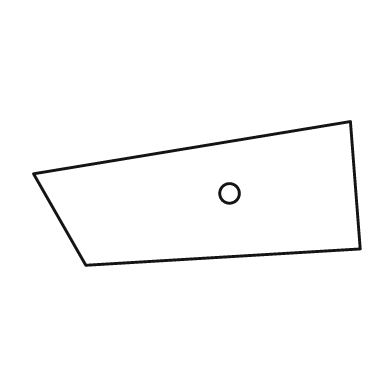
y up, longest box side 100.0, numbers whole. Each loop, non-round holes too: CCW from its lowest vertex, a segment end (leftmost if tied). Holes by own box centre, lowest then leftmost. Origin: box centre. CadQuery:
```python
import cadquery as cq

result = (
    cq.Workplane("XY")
    .moveTo(-34.0, -22.0)
    .lineTo(50.0, -17.0)
    .lineTo(47.0, 22.0)
    .lineTo(-50.0, 6.0)
    .close()
    .moveTo(10.0, 0.0)
    .circle(3.0)
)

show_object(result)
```